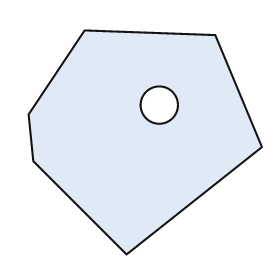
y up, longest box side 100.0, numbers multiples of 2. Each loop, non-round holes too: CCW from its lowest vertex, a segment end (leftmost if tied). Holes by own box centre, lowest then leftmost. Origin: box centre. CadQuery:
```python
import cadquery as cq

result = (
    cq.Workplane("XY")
    .moveTo(-8.0, -48.0)
    .lineTo(50.0, -2.0)
    .lineTo(30.0, 46.0)
    .lineTo(-26.0, 48.0)
    .lineTo(-50.0, 12.0)
    .lineTo(-48.0, -8.0)
    .close()
    .moveTo(6.0, 16.0)
    .circle(8.0)
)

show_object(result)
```